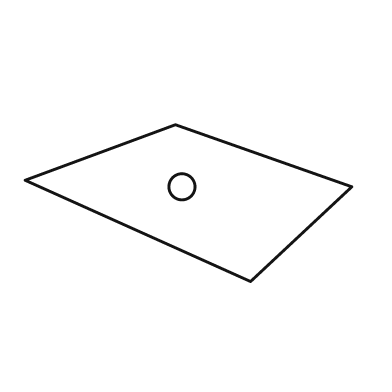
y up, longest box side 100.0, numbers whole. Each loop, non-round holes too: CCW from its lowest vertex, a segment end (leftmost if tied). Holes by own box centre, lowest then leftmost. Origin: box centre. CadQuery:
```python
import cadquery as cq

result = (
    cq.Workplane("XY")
    .moveTo(19.0, -24.0)
    .lineTo(50.0, 5.0)
    .lineTo(-4.0, 24.0)
    .lineTo(-50.0, 7.0)
    .close()
    .moveTo(-2.0, 5.0)
    .circle(4.0)
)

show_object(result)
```